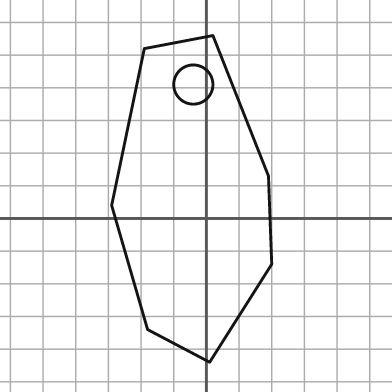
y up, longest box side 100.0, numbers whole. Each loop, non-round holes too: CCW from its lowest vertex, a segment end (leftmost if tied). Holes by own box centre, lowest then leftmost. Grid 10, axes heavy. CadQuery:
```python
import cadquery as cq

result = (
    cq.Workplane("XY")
    .moveTo(1.0, -44.0)
    .lineTo(20.0, -14.0)
    .lineTo(19.0, 13.0)
    .lineTo(2.0, 56.0)
    .lineTo(-19.0, 52.0)
    .lineTo(-29.0, 4.0)
    .lineTo(-18.0, -34.0)
    .close()
    .moveTo(-4.0, 41.0)
    .circle(6.0)
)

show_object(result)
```